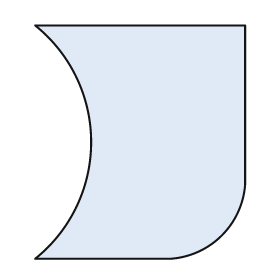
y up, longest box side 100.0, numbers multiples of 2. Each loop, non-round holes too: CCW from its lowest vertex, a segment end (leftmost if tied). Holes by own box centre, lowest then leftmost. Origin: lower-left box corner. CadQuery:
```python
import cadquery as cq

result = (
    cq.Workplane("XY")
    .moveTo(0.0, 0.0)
    .lineTo(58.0, 0.0)
    .threePointArc((80.0, 10.0), (90.0, 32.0))
    .lineTo(90.0, 100.0)
    .lineTo(0.0, 100.0)
    .threePointArc((24.0, 50.0), (0.0, 0.0))
    .close()
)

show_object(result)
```